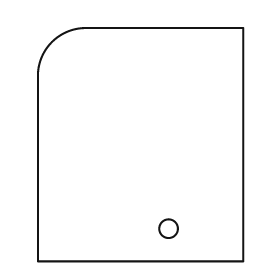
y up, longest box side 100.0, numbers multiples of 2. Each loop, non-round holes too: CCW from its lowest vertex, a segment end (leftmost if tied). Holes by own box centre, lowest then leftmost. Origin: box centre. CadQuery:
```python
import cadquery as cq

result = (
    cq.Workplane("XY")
    .moveTo(-44.0, -50.0)
    .lineTo(44.0, -50.0)
    .lineTo(44.0, 50.0)
    .lineTo(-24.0, 50.0)
    .threePointArc((-38.0, 44.0), (-44.0, 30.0))
    .close()
    .moveTo(12.0, -36.0)
    .circle(4.0)
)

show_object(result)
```